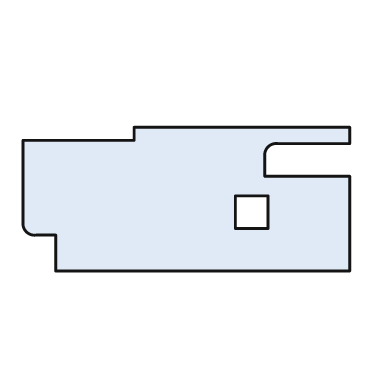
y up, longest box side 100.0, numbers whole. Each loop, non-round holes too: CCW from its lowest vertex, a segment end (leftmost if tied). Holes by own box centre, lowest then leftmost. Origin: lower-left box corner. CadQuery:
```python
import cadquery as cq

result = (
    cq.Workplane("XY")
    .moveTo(10.0, 0.0)
    .lineTo(100.0, 0.0)
    .lineTo(100.0, 29.0)
    .lineTo(74.0, 29.0)
    .lineTo(74.0, 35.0)
    .threePointArc((75.0, 38.0), (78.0, 39.0))
    .lineTo(100.0, 39.0)
    .lineTo(100.0, 44.0)
    .lineTo(34.0, 44.0)
    .lineTo(34.0, 40.0)
    .lineTo(0.0, 40.0)
    .lineTo(0.0, 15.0)
    .threePointArc((1.0, 12.0), (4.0, 11.0))
    .lineTo(10.0, 11.0)
    .close()
    .moveTo(65.0, 13.0)
    .lineTo(75.0, 13.0)
    .lineTo(75.0, 23.0)
    .lineTo(65.0, 23.0)
    .close()
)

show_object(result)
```